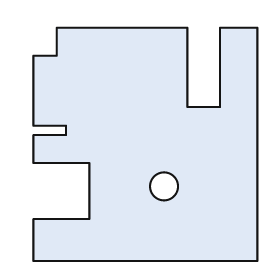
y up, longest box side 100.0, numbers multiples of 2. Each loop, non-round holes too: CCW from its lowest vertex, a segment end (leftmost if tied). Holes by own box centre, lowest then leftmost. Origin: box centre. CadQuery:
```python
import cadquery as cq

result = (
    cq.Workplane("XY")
    .moveTo(-48.0, -50.0)
    .lineTo(48.0, -50.0)
    .lineTo(48.0, 50.0)
    .lineTo(32.0, 50.0)
    .lineTo(32.0, 16.0)
    .lineTo(18.0, 16.0)
    .lineTo(18.0, 50.0)
    .lineTo(-38.0, 50.0)
    .lineTo(-38.0, 38.0)
    .lineTo(-48.0, 38.0)
    .lineTo(-48.0, 8.0)
    .lineTo(-34.0, 8.0)
    .lineTo(-34.0, 4.0)
    .lineTo(-48.0, 4.0)
    .lineTo(-48.0, -8.0)
    .lineTo(-24.0, -8.0)
    .lineTo(-24.0, -32.0)
    .lineTo(-48.0, -32.0)
    .close()
    .moveTo(8.0, -18.0)
    .circle(6.0)
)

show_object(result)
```